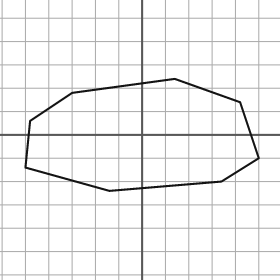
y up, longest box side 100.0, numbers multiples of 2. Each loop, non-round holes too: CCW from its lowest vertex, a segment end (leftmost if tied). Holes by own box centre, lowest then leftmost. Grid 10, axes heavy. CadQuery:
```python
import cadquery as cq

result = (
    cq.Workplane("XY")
    .moveTo(-14.0, -24.0)
    .lineTo(34.0, -20.0)
    .lineTo(50.0, -10.0)
    .lineTo(42.0, 14.0)
    .lineTo(14.0, 24.0)
    .lineTo(-30.0, 18.0)
    .lineTo(-48.0, 6.0)
    .lineTo(-50.0, -14.0)
    .close()
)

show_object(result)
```